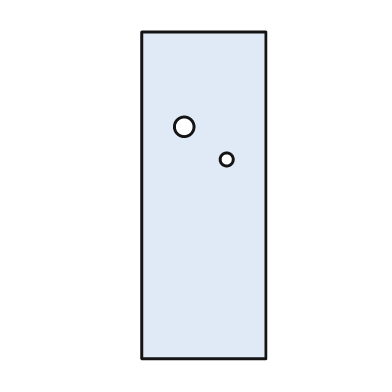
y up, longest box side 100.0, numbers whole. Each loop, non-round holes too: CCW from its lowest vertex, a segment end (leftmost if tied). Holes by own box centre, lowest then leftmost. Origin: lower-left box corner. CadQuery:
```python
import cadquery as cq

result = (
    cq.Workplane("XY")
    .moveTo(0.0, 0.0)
    .lineTo(38.0, 0.0)
    .lineTo(38.0, 100.0)
    .lineTo(0.0, 100.0)
    .close()
    .moveTo(26.0, 61.0)
    .circle(2.0)
    .moveTo(13.0, 71.0)
    .circle(3.0)
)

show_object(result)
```